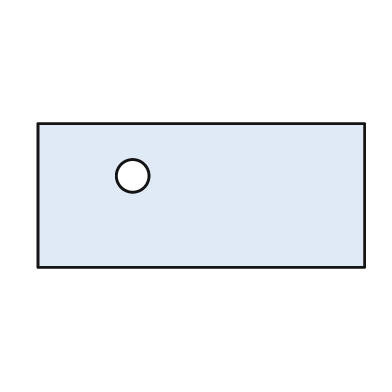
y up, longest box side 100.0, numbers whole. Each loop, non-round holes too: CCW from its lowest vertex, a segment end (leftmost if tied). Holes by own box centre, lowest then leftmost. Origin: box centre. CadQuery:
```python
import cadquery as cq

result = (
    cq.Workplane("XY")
    .moveTo(-50.0, -22.0)
    .lineTo(50.0, -22.0)
    .lineTo(50.0, 22.0)
    .lineTo(-50.0, 22.0)
    .close()
    .moveTo(-21.0, 6.0)
    .circle(5.0)
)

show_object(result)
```